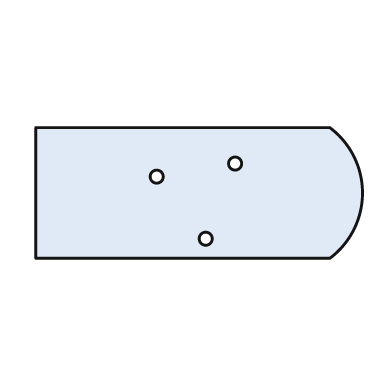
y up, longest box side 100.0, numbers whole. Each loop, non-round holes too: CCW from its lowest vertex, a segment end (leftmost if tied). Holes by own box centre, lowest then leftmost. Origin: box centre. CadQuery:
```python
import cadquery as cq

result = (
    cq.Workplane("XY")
    .moveTo(-50.0, -20.0)
    .lineTo(40.0, -20.0)
    .threePointArc((50.0, 0.0), (40.0, 20.0))
    .lineTo(-50.0, 20.0)
    .close()
    .moveTo(2.0, -14.0)
    .circle(2.0)
    .moveTo(-13.0, 5.0)
    .circle(2.0)
    .moveTo(11.0, 9.0)
    .circle(2.0)
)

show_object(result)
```